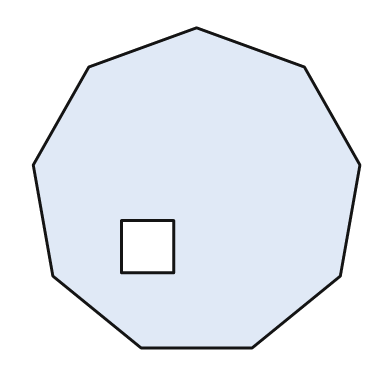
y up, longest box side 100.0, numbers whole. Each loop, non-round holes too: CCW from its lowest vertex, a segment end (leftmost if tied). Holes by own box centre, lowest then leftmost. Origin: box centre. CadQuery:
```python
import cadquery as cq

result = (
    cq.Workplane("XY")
    .moveTo(-17.0, -49.0)
    .lineTo(17.0, -49.0)
    .lineTo(44.0, -27.0)
    .lineTo(50.0, 7.0)
    .lineTo(33.0, 37.0)
    .lineTo(0.0, 49.0)
    .lineTo(-33.0, 37.0)
    .lineTo(-50.0, 7.0)
    .lineTo(-44.0, -27.0)
    .close()
    .moveTo(-23.0, -26.0)
    .lineTo(-7.0, -26.0)
    .lineTo(-7.0, -10.0)
    .lineTo(-23.0, -10.0)
    .close()
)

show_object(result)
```